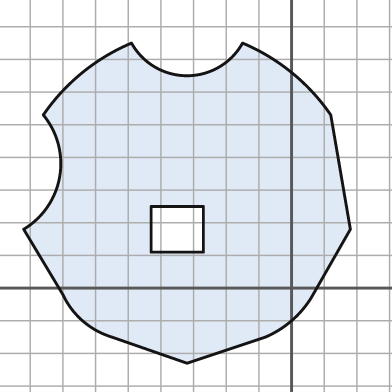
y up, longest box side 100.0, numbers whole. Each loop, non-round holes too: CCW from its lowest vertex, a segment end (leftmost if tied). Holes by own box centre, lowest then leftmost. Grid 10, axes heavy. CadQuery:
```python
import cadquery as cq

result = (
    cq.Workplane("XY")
    .moveTo(-32.0, -23.0)
    .lineTo(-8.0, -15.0)
    .threePointArc((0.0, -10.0), (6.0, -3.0))
    .lineTo(18.0, 18.0)
    .lineTo(12.0, 53.0)
    .threePointArc((0.0, 66.0), (-15.0, 75.0))
    .threePointArc((-32.0, 65.0), (-49.0, 75.0))
    .threePointArc((-64.0, 66.0), (-76.0, 53.0))
    .threePointArc((-71.0, 34.0), (-82.0, 18.0))
    .lineTo(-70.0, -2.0)
    .threePointArc((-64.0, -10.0), (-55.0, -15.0))
    .close()
    .moveTo(-43.0, 11.0)
    .lineTo(-27.0, 11.0)
    .lineTo(-27.0, 25.0)
    .lineTo(-43.0, 25.0)
    .close()
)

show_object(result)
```